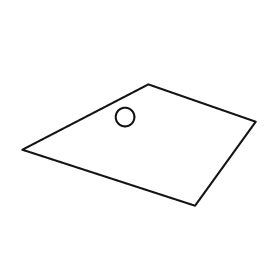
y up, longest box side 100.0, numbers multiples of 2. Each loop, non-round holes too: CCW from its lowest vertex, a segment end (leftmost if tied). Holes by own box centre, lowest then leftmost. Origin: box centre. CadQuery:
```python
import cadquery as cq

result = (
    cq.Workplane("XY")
    .moveTo(24.0, -26.0)
    .lineTo(50.0, 10.0)
    .lineTo(4.0, 26.0)
    .lineTo(-50.0, -2.0)
    .close()
    .moveTo(-6.0, 12.0)
    .circle(4.0)
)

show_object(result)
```